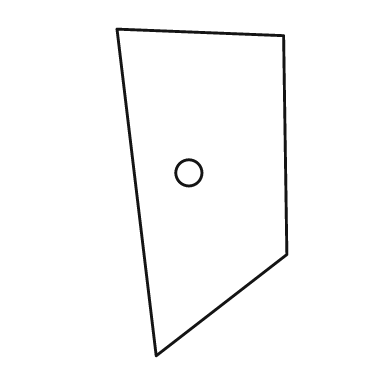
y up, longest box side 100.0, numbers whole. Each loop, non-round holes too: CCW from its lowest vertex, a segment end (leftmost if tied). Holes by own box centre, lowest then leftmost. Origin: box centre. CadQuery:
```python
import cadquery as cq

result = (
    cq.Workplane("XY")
    .moveTo(-14.0, -50.0)
    .lineTo(26.0, -19.0)
    .lineTo(25.0, 48.0)
    .lineTo(-26.0, 50.0)
    .close()
    .moveTo(-4.0, 6.0)
    .circle(4.0)
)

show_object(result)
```